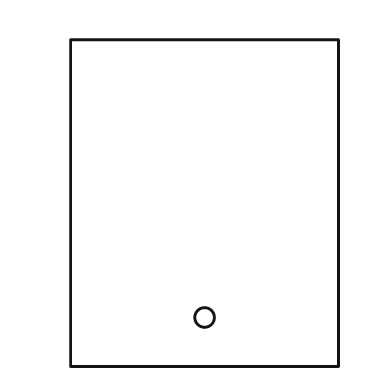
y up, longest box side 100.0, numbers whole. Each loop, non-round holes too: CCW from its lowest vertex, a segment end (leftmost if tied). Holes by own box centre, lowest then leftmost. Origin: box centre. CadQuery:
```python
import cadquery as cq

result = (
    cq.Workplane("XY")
    .moveTo(-41.0, -50.0)
    .lineTo(41.0, -50.0)
    .lineTo(41.0, 50.0)
    .lineTo(-41.0, 50.0)
    .close()
    .moveTo(0.0, -35.0)
    .circle(3.0)
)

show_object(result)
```